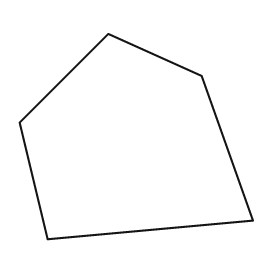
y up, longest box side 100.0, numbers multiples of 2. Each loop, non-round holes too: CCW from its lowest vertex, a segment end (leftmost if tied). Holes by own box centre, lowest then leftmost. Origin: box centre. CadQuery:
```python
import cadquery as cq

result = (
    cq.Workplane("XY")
    .moveTo(-38.0, -44.0)
    .lineTo(50.0, -36.0)
    .lineTo(28.0, 26.0)
    .lineTo(-12.0, 44.0)
    .lineTo(-50.0, 6.0)
    .close()
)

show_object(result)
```